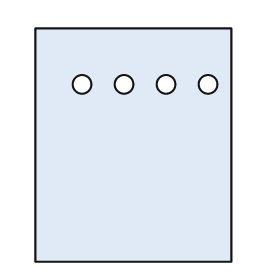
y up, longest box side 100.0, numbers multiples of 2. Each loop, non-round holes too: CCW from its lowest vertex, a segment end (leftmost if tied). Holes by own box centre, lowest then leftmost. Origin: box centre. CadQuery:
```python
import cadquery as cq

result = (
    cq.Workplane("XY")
    .moveTo(-42.0, -50.0)
    .lineTo(42.0, -50.0)
    .lineTo(42.0, 50.0)
    .lineTo(-42.0, 50.0)
    .close()
    .moveTo(-22.0, 26.0)
    .circle(4.0)
    .moveTo(-4.0, 26.0)
    .circle(4.0)
    .moveTo(14.0, 26.0)
    .circle(4.0)
    .moveTo(32.0, 26.0)
    .circle(4.0)
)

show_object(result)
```